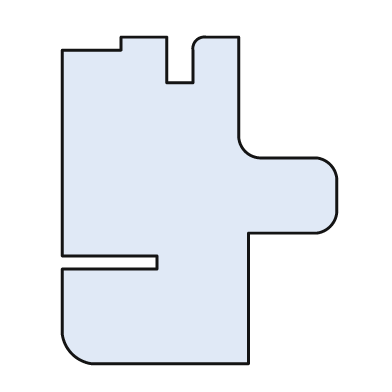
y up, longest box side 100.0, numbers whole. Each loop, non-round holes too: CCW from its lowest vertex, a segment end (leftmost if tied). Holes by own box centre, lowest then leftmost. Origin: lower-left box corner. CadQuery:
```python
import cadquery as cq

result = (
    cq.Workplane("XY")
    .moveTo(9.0, 0.0)
    .lineTo(57.0, 0.0)
    .lineTo(57.0, 40.0)
    .lineTo(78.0, 40.0)
    .threePointArc((82.0, 42.0), (84.0, 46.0))
    .lineTo(84.0, 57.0)
    .threePointArc((82.0, 61.0), (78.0, 63.0))
    .lineTo(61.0, 63.0)
    .threePointArc((56.0, 65.0), (54.0, 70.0))
    .lineTo(54.0, 100.0)
    .lineTo(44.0, 100.0)
    .threePointArc((41.0, 99.0), (40.0, 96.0))
    .lineTo(40.0, 86.0)
    .lineTo(32.0, 86.0)
    .lineTo(32.0, 100.0)
    .lineTo(18.0, 100.0)
    .lineTo(18.0, 96.0)
    .lineTo(0.0, 96.0)
    .lineTo(0.0, 33.0)
    .lineTo(29.0, 33.0)
    .lineTo(29.0, 29.0)
    .lineTo(0.0, 29.0)
    .lineTo(0.0, 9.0)
    .threePointArc((3.0, 3.0), (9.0, 0.0))
    .close()
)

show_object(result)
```